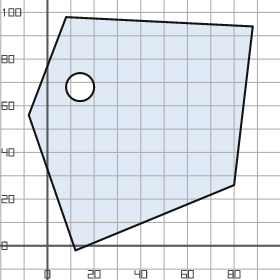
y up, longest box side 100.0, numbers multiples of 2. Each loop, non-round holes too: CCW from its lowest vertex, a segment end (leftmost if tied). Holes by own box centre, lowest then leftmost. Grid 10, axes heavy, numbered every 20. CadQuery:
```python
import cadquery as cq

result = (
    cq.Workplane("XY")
    .moveTo(12.0, -2.0)
    .lineTo(80.0, 26.0)
    .lineTo(88.0, 94.0)
    .lineTo(8.0, 98.0)
    .lineTo(-8.0, 56.0)
    .close()
    .moveTo(14.0, 68.0)
    .circle(6.0)
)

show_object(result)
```